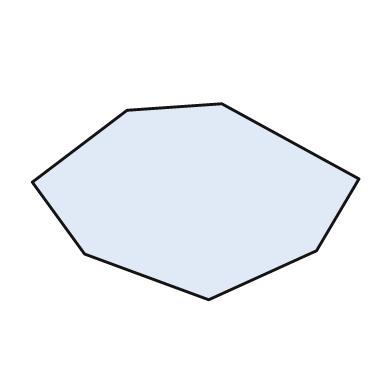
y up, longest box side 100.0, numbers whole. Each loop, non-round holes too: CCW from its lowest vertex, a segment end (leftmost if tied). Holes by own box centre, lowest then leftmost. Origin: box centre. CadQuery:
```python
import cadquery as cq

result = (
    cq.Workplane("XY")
    .moveTo(4.0, -30.0)
    .lineTo(37.0, -15.0)
    .lineTo(50.0, 7.0)
    .lineTo(8.0, 30.0)
    .lineTo(-21.0, 28.0)
    .lineTo(-50.0, 6.0)
    .lineTo(-34.0, -16.0)
    .close()
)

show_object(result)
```